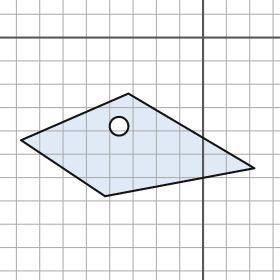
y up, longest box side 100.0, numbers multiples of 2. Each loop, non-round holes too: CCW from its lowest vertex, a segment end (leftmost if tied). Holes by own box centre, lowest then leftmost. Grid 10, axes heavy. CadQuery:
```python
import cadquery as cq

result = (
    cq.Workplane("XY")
    .moveTo(-42.0, -68.0)
    .lineTo(22.0, -56.0)
    .lineTo(-32.0, -24.0)
    .lineTo(-78.0, -44.0)
    .close()
    .moveTo(-36.0, -38.0)
    .circle(4.0)
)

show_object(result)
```